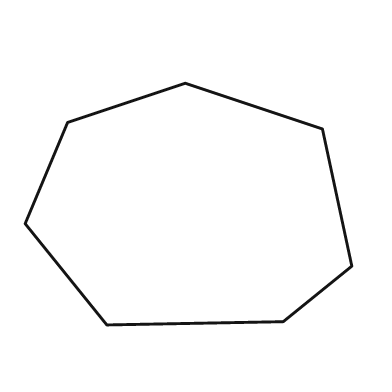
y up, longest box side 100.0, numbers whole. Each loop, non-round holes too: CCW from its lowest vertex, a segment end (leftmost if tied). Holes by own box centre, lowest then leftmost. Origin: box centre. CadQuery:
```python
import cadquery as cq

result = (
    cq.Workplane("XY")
    .moveTo(-25.0, -37.0)
    .lineTo(29.0, -36.0)
    .lineTo(50.0, -19.0)
    .lineTo(41.0, 23.0)
    .lineTo(-1.0, 37.0)
    .lineTo(-37.0, 25.0)
    .lineTo(-50.0, -6.0)
    .close()
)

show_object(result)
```